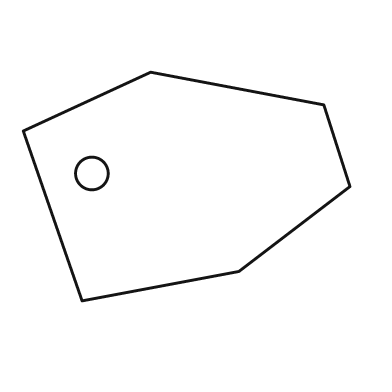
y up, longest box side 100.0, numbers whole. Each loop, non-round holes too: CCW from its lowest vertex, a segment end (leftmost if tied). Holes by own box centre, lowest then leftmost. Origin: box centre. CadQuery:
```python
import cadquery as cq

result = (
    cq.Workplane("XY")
    .moveTo(-32.0, -35.0)
    .lineTo(16.0, -26.0)
    .lineTo(50.0, 0.0)
    .lineTo(42.0, 25.0)
    .lineTo(-11.0, 35.0)
    .lineTo(-50.0, 17.0)
    .close()
    .moveTo(-29.0, 4.0)
    .circle(5.0)
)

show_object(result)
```